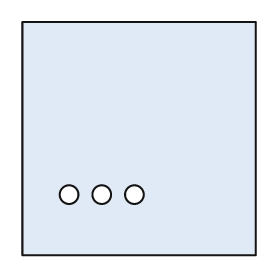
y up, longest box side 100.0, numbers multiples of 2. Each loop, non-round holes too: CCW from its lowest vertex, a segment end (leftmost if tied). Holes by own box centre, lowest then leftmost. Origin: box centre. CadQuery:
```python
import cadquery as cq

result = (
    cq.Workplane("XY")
    .moveTo(-50.0, -50.0)
    .lineTo(50.0, -50.0)
    .lineTo(50.0, 50.0)
    .lineTo(-50.0, 50.0)
    .close()
    .moveTo(-30.0, -24.0)
    .circle(4.0)
    .moveTo(-16.0, -24.0)
    .circle(4.0)
    .moveTo(-2.0, -24.0)
    .circle(4.0)
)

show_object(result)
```